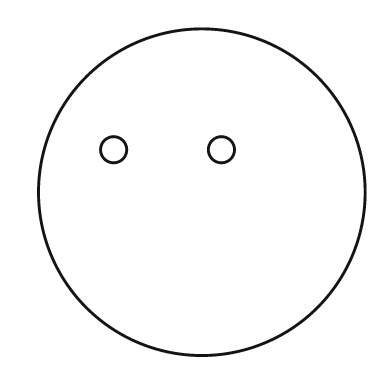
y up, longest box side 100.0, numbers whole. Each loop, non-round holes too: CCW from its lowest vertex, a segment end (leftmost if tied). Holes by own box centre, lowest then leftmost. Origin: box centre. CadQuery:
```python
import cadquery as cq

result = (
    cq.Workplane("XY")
    .moveTo(0.0, 0.0)
    .circle(50.0)
    .moveTo(-27.0, 13.0)
    .circle(4.0)
    .moveTo(6.0, 13.0)
    .circle(4.0)
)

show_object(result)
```